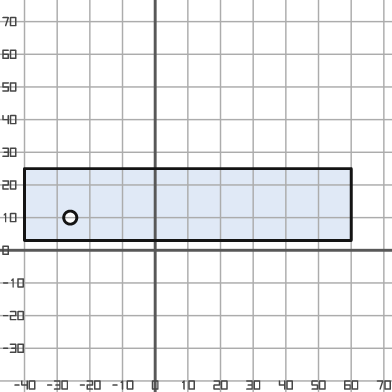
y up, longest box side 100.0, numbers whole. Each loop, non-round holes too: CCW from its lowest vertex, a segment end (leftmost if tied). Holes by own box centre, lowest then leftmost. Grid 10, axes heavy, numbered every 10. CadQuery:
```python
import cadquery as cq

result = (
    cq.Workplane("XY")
    .moveTo(-40.0, 3.0)
    .lineTo(60.0, 3.0)
    .lineTo(60.0, 25.0)
    .lineTo(-40.0, 25.0)
    .close()
    .moveTo(-26.0, 10.0)
    .circle(2.0)
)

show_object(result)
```